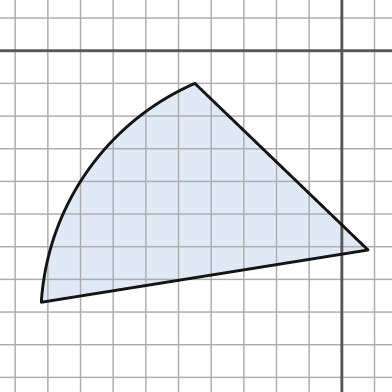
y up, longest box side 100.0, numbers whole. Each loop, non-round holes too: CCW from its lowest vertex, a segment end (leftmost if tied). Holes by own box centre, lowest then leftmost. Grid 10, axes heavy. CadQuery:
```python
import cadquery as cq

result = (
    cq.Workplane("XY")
    .moveTo(-92.0, -77.0)
    .lineTo(8.0, -61.0)
    .lineTo(-45.0, -10.0)
    .threePointArc((-78.0, -37.0), (-92.0, -77.0))
    .close()
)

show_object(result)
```